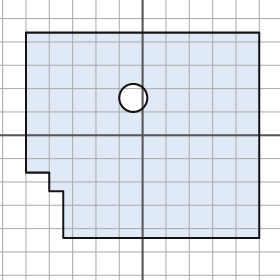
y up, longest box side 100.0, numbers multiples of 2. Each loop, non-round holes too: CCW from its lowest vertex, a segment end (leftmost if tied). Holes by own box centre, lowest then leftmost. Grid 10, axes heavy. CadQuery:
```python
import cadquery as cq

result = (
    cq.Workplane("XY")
    .moveTo(-34.0, -44.0)
    .lineTo(50.0, -44.0)
    .lineTo(50.0, 44.0)
    .lineTo(-50.0, 44.0)
    .lineTo(-50.0, -16.0)
    .lineTo(-40.0, -16.0)
    .lineTo(-40.0, -24.0)
    .lineTo(-34.0, -24.0)
    .close()
    .moveTo(-4.0, 16.0)
    .circle(6.0)
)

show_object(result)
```